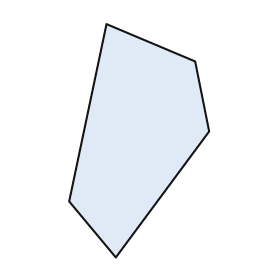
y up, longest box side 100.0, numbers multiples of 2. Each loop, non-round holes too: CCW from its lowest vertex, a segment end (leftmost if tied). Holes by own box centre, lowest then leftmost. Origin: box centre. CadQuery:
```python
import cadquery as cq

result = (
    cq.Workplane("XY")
    .moveTo(-10.0, -50.0)
    .lineTo(30.0, 4.0)
    .lineTo(24.0, 34.0)
    .lineTo(-14.0, 50.0)
    .lineTo(-30.0, -26.0)
    .close()
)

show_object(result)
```